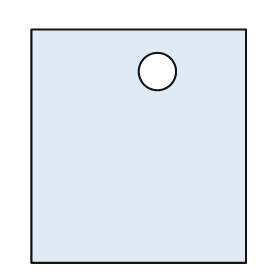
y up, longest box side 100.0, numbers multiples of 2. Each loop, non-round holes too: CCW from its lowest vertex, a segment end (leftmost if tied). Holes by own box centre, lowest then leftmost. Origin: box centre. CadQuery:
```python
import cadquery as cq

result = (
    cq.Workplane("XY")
    .moveTo(-46.0, -50.0)
    .lineTo(46.0, -50.0)
    .lineTo(46.0, 50.0)
    .lineTo(-46.0, 50.0)
    .close()
    .moveTo(8.0, 32.0)
    .circle(8.0)
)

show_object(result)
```